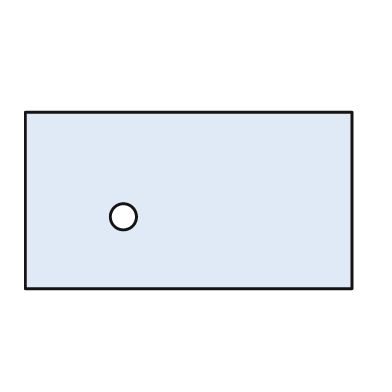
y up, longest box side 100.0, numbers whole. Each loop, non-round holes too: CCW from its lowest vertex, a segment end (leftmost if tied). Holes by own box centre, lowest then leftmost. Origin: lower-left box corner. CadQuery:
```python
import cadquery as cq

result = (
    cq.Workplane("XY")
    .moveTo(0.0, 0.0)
    .lineTo(100.0, 0.0)
    .lineTo(100.0, 54.0)
    .lineTo(0.0, 54.0)
    .close()
    .moveTo(30.0, 22.0)
    .circle(4.0)
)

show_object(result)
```